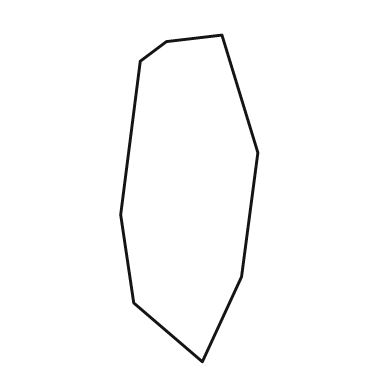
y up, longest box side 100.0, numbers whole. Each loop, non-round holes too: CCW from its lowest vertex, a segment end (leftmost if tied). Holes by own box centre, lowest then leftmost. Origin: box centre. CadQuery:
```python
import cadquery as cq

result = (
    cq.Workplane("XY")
    .moveTo(4.0, -50.0)
    .lineTo(16.0, -24.0)
    .lineTo(21.0, 14.0)
    .lineTo(10.0, 50.0)
    .lineTo(-7.0, 48.0)
    .lineTo(-15.0, 42.0)
    .lineTo(-21.0, -5.0)
    .lineTo(-17.0, -32.0)
    .close()
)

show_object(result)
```